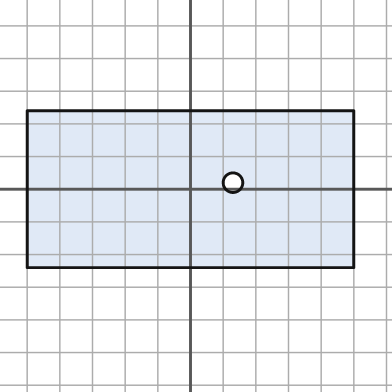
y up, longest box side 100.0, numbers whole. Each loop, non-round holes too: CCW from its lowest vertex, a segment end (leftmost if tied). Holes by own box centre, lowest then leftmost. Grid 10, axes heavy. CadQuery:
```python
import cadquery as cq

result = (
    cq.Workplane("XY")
    .moveTo(-50.0, -24.0)
    .lineTo(50.0, -24.0)
    .lineTo(50.0, 24.0)
    .lineTo(-50.0, 24.0)
    .close()
    .moveTo(13.0, 2.0)
    .circle(3.0)
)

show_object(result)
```